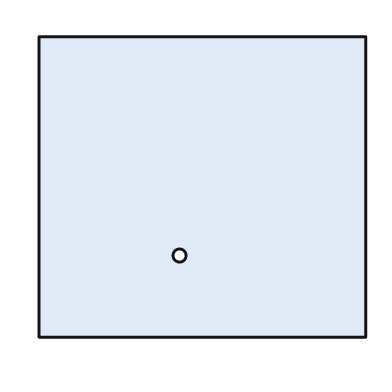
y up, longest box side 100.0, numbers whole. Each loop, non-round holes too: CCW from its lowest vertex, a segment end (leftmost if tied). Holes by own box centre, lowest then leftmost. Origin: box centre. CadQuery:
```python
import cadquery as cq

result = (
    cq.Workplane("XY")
    .moveTo(-50.0, -46.0)
    .lineTo(50.0, -46.0)
    .lineTo(50.0, 46.0)
    .lineTo(-50.0, 46.0)
    .close()
    .moveTo(-7.0, -21.0)
    .circle(2.0)
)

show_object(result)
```